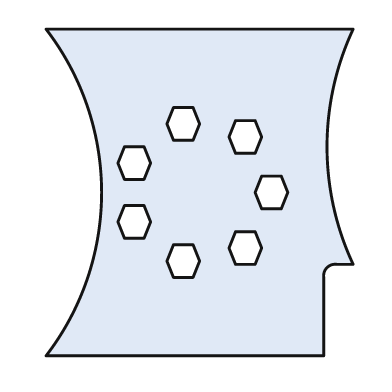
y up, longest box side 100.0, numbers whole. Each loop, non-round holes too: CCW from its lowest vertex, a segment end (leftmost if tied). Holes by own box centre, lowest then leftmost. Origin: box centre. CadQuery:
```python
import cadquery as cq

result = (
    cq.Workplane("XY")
    .moveTo(-47.0, -50.0)
    .lineTo(38.0, -50.0)
    .lineTo(38.0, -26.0)
    .threePointArc((39.0, -23.0), (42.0, -22.0))
    .lineTo(47.0, -22.0)
    .threePointArc((39.0, 14.0), (47.0, 50.0))
    .lineTo(-47.0, 50.0)
    .threePointArc((-30.0, 0.0), (-47.0, -50.0))
    .close()
    .moveTo(-8.0, -26.0)
    .lineTo(-2.0, -26.0)
    .lineTo(0.0, -21.0)
    .lineTo(-2.0, -16.0)
    .lineTo(-8.0, -16.0)
    .lineTo(-10.0, -21.0)
    .close()
    .moveTo(11.0, -22.0)
    .lineTo(17.0, -22.0)
    .lineTo(19.0, -17.0)
    .lineTo(17.0, -12.0)
    .lineTo(11.0, -12.0)
    .lineTo(9.0, -17.0)
    .close()
    .moveTo(-23.0, -14.0)
    .lineTo(-17.0, -14.0)
    .lineTo(-15.0, -9.0)
    .lineTo(-17.0, -4.0)
    .lineTo(-23.0, -4.0)
    .lineTo(-25.0, -9.0)
    .close()
    .moveTo(19.0, -5.0)
    .lineTo(25.0, -5.0)
    .lineTo(27.0, 0.0)
    .lineTo(25.0, 5.0)
    .lineTo(19.0, 5.0)
    .lineTo(17.0, 0.0)
    .close()
    .moveTo(-23.0, 4.0)
    .lineTo(-17.0, 4.0)
    .lineTo(-15.0, 9.0)
    .lineTo(-17.0, 14.0)
    .lineTo(-23.0, 14.0)
    .lineTo(-25.0, 9.0)
    .close()
    .moveTo(11.0, 12.0)
    .lineTo(17.0, 12.0)
    .lineTo(19.0, 17.0)
    .lineTo(17.0, 22.0)
    .lineTo(11.0, 22.0)
    .lineTo(9.0, 17.0)
    .close()
    .moveTo(-8.0, 16.0)
    .lineTo(-2.0, 16.0)
    .lineTo(0.0, 21.0)
    .lineTo(-2.0, 26.0)
    .lineTo(-8.0, 26.0)
    .lineTo(-10.0, 21.0)
    .close()
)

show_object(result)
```